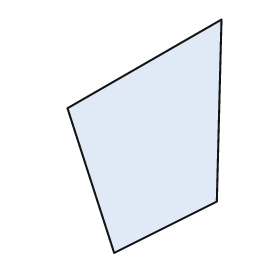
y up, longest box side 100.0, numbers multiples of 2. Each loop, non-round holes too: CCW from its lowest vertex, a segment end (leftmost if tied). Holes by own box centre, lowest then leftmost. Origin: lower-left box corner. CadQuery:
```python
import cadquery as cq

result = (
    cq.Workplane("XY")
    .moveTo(20.0, 0.0)
    .lineTo(64.0, 22.0)
    .lineTo(66.0, 100.0)
    .lineTo(0.0, 62.0)
    .close()
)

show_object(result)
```